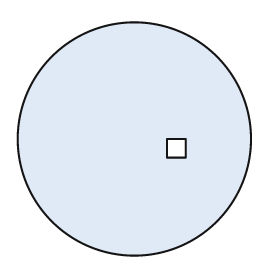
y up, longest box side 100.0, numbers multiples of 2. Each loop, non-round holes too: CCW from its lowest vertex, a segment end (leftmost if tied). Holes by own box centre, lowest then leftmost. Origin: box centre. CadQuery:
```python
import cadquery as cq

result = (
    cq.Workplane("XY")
    .moveTo(0.0, 0.0)
    .circle(50.0)
    .moveTo(14.0, -8.0)
    .lineTo(22.0, -8.0)
    .lineTo(22.0, 0.0)
    .lineTo(14.0, 0.0)
    .close()
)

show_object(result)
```